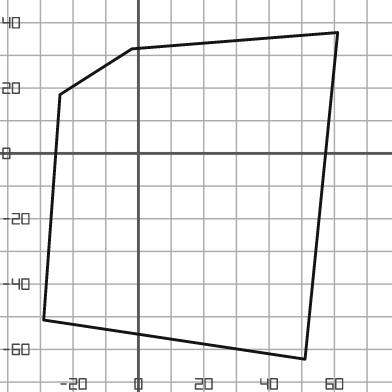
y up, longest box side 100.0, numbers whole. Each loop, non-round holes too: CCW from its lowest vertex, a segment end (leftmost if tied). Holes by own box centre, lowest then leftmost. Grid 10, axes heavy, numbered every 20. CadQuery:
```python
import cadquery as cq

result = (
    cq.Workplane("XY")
    .moveTo(51.0, -63.0)
    .lineTo(61.0, 37.0)
    .lineTo(-2.0, 32.0)
    .lineTo(-24.0, 18.0)
    .lineTo(-29.0, -51.0)
    .close()
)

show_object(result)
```